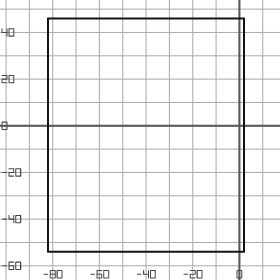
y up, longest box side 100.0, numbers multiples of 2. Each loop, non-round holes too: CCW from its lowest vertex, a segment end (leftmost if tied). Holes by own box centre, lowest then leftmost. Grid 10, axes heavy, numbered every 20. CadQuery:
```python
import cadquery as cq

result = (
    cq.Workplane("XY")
    .moveTo(-82.0, -54.0)
    .lineTo(2.0, -54.0)
    .lineTo(2.0, 46.0)
    .lineTo(-82.0, 46.0)
    .close()
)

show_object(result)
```